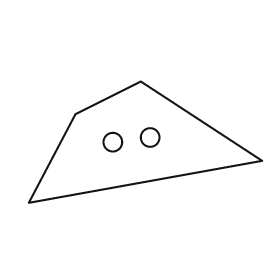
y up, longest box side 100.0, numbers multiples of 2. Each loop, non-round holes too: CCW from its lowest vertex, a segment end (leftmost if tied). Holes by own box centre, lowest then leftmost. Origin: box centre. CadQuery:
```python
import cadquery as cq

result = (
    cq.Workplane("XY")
    .moveTo(-50.0, -26.0)
    .lineTo(50.0, -8.0)
    .lineTo(-2.0, 26.0)
    .lineTo(-30.0, 12.0)
    .close()
    .moveTo(-14.0, 0.0)
    .circle(4.0)
    .moveTo(2.0, 2.0)
    .circle(4.0)
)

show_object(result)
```